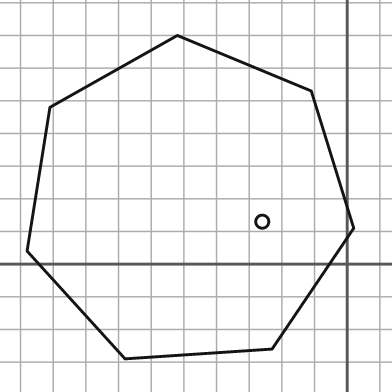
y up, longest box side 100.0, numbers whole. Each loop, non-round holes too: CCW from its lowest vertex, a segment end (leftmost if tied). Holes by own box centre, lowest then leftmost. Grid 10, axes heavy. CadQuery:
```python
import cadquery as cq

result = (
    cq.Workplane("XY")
    .moveTo(-68.0, -29.0)
    .lineTo(-23.0, -26.0)
    .lineTo(2.0, 11.0)
    .lineTo(-11.0, 53.0)
    .lineTo(-52.0, 70.0)
    .lineTo(-91.0, 48.0)
    .lineTo(-98.0, 4.0)
    .close()
    .moveTo(-26.0, 13.0)
    .circle(2.0)
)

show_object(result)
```